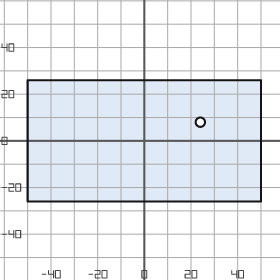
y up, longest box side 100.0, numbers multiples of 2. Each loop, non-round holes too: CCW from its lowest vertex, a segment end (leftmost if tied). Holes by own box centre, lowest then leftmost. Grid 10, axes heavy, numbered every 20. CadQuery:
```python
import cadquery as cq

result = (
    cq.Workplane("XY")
    .moveTo(-50.0, -26.0)
    .lineTo(50.0, -26.0)
    .lineTo(50.0, 26.0)
    .lineTo(-50.0, 26.0)
    .close()
    .moveTo(24.0, 8.0)
    .circle(2.0)
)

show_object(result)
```